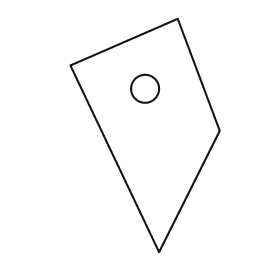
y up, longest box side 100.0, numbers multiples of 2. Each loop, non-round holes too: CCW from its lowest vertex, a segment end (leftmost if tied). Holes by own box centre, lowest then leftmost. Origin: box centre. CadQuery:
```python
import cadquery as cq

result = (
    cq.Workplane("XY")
    .moveTo(6.0, -50.0)
    .lineTo(32.0, 2.0)
    .lineTo(14.0, 50.0)
    .lineTo(-32.0, 30.0)
    .close()
    .moveTo(0.0, 20.0)
    .circle(6.0)
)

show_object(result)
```